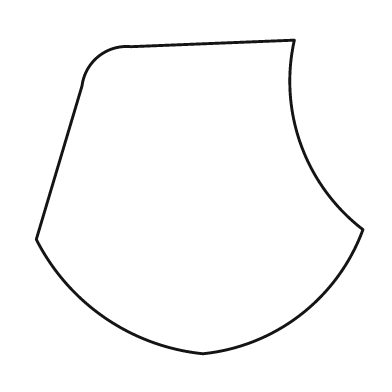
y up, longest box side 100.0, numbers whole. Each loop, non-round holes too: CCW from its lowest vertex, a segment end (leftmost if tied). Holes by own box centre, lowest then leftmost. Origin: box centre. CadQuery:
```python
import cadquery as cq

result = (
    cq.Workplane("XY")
    .moveTo(1.0, -48.0)
    .threePointArc((31.0, -36.0), (50.0, -10.0))
    .threePointArc((31.0, 16.0), (29.0, 48.0))
    .lineTo(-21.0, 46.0)
    .threePointArc((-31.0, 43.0), (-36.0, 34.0))
    .lineTo(-50.0, -13.0)
    .threePointArc((-29.0, -37.0), (1.0, -48.0))
    .close()
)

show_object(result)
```